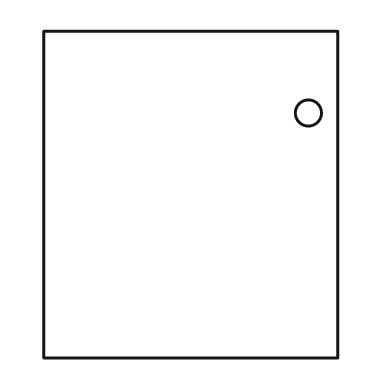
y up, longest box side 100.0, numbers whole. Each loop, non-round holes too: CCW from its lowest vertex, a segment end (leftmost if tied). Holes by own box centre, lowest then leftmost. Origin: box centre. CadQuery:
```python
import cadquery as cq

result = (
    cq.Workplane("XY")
    .moveTo(-45.0, -50.0)
    .lineTo(45.0, -50.0)
    .lineTo(45.0, 50.0)
    .lineTo(-45.0, 50.0)
    .close()
    .moveTo(36.0, 25.0)
    .circle(4.0)
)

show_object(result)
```